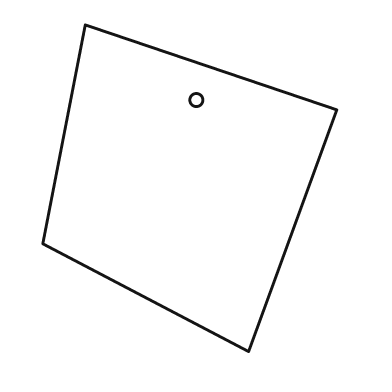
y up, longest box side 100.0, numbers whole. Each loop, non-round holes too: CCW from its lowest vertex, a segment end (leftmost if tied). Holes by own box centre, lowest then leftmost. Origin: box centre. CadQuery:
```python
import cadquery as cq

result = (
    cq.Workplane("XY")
    .moveTo(18.0, -50.0)
    .lineTo(45.0, 24.0)
    .lineTo(-32.0, 50.0)
    .lineTo(-45.0, -17.0)
    .close()
    .moveTo(2.0, 27.0)
    .circle(2.0)
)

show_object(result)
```